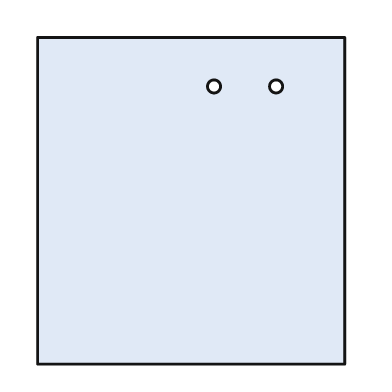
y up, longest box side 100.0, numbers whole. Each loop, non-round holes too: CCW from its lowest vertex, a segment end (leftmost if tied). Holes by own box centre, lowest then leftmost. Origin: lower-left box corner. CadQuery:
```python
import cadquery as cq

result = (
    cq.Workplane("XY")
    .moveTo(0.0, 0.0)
    .lineTo(94.0, 0.0)
    .lineTo(94.0, 100.0)
    .lineTo(0.0, 100.0)
    .close()
    .moveTo(54.0, 85.0)
    .circle(2.0)
    .moveTo(73.0, 85.0)
    .circle(2.0)
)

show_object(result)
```